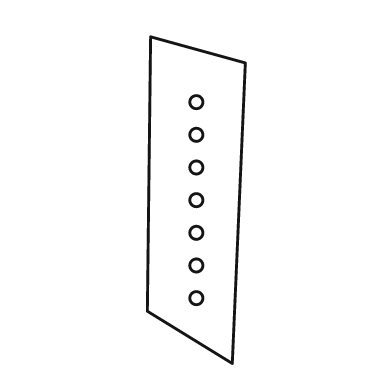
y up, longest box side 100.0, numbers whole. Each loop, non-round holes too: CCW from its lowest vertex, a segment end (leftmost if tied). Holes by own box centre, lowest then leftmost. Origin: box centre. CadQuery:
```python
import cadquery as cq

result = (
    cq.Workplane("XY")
    .moveTo(11.0, -50.0)
    .lineTo(15.0, 42.0)
    .lineTo(-14.0, 50.0)
    .lineTo(-15.0, -34.0)
    .close()
    .moveTo(0.0, -30.0)
    .circle(2.0)
    .moveTo(0.0, -20.0)
    .circle(2.0)
    .moveTo(0.0, -10.0)
    .circle(2.0)
    .moveTo(0.0, 0.0)
    .circle(2.0)
    .moveTo(0.0, 10.0)
    .circle(2.0)
    .moveTo(0.0, 20.0)
    .circle(2.0)
    .moveTo(0.0, 30.0)
    .circle(2.0)
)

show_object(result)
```